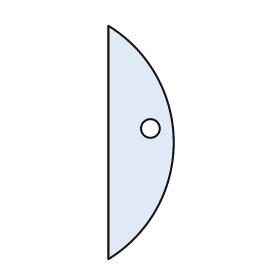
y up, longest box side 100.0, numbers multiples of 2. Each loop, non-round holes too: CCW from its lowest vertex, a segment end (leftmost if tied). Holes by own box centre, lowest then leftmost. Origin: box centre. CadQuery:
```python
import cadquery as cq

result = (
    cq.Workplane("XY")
    .moveTo(-14.0, -50.0)
    .threePointArc((14.0, 0.0), (-14.0, 50.0))
    .close()
    .moveTo(4.0, 6.0)
    .circle(4.0)
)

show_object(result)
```